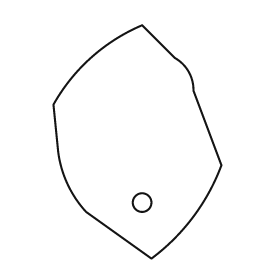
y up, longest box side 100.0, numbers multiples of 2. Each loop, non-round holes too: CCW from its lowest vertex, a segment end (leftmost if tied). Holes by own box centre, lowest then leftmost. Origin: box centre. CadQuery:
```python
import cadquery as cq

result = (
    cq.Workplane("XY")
    .moveTo(6.0, -50.0)
    .threePointArc((24.0, -32.0), (36.0, -10.0))
    .lineTo(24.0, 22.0)
    .threePointArc((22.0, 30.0), (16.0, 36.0))
    .lineTo(2.0, 50.0)
    .threePointArc((-20.0, 36.0), (-36.0, 16.0))
    .lineTo(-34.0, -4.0)
    .threePointArc((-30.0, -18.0), (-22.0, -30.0))
    .close()
    .moveTo(2.0, -26.0)
    .circle(4.0)
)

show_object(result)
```